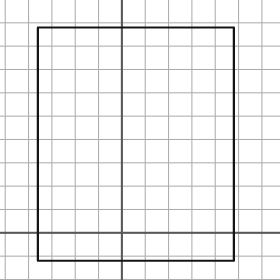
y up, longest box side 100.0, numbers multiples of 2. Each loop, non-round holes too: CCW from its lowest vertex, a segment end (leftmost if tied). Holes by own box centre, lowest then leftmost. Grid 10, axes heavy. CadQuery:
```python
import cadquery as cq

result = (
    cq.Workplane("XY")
    .moveTo(-36.0, -12.0)
    .lineTo(48.0, -12.0)
    .lineTo(48.0, 88.0)
    .lineTo(-36.0, 88.0)
    .close()
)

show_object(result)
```